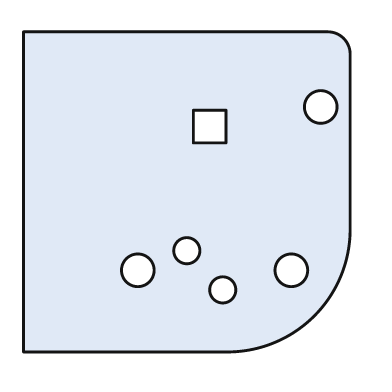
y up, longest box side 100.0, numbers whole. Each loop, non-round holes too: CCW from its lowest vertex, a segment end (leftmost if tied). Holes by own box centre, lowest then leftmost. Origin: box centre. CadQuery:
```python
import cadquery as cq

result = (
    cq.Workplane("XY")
    .moveTo(-50.0, -49.0)
    .lineTo(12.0, -49.0)
    .threePointArc((39.0, -38.0), (50.0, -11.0))
    .lineTo(50.0, 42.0)
    .threePointArc((48.0, 47.0), (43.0, 49.0))
    .lineTo(-50.0, 49.0)
    .close()
    .moveTo(11.0, -30.0)
    .circle(4.0)
    .moveTo(-15.0, -24.0)
    .circle(5.0)
    .moveTo(32.0, -24.0)
    .circle(5.0)
    .moveTo(0.0, -18.0)
    .circle(4.0)
    .moveTo(2.0, 15.0)
    .lineTo(12.0, 15.0)
    .lineTo(12.0, 25.0)
    .lineTo(2.0, 25.0)
    .close()
    .moveTo(41.0, 26.0)
    .circle(5.0)
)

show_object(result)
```